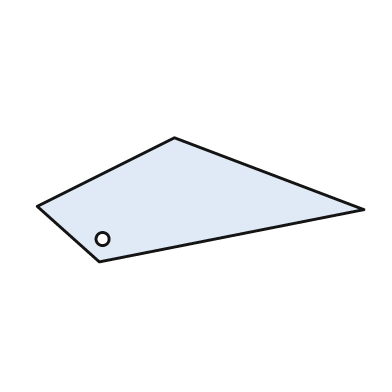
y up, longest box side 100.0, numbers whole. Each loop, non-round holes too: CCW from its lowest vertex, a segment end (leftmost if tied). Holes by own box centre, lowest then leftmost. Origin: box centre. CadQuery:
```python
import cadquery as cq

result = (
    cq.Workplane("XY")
    .moveTo(-31.0, -19.0)
    .lineTo(50.0, -3.0)
    .lineTo(-8.0, 19.0)
    .lineTo(-50.0, -2.0)
    .close()
    .moveTo(-30.0, -12.0)
    .circle(2.0)
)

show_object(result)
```